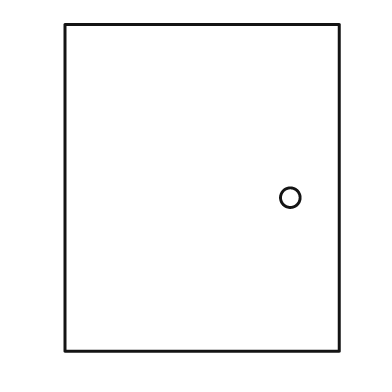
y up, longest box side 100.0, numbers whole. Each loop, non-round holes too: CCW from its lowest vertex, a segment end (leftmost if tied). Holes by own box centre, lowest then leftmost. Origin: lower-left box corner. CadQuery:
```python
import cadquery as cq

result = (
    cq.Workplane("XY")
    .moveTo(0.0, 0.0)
    .lineTo(84.0, 0.0)
    .lineTo(84.0, 100.0)
    .lineTo(0.0, 100.0)
    .close()
    .moveTo(69.0, 47.0)
    .circle(3.0)
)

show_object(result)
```